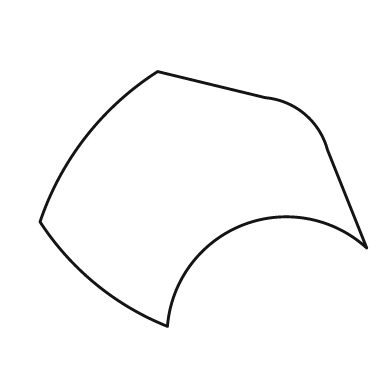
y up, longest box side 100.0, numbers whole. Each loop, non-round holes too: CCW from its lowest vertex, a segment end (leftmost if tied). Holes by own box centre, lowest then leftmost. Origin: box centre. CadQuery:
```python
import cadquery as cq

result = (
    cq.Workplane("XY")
    .moveTo(-11.0, -39.0)
    .threePointArc((12.0, -8.0), (50.0, -15.0))
    .lineTo(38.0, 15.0)
    .threePointArc((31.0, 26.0), (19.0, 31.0))
    .lineTo(-14.0, 39.0)
    .threePointArc((-36.0, 19.0), (-50.0, -7.0))
    .threePointArc((-33.0, -26.0), (-11.0, -39.0))
    .close()
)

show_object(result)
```